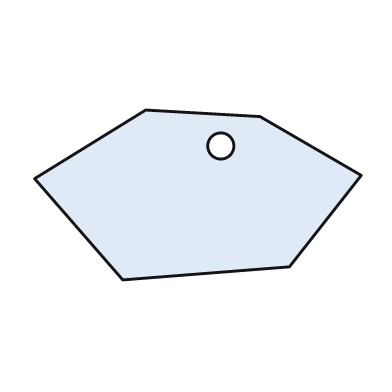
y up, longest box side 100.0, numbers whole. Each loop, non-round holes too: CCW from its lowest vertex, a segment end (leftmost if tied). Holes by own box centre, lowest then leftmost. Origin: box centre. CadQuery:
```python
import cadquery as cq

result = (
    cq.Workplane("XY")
    .moveTo(-23.0, -26.0)
    .lineTo(28.0, -22.0)
    .lineTo(50.0, 6.0)
    .lineTo(19.0, 24.0)
    .lineTo(-16.0, 26.0)
    .lineTo(-50.0, 5.0)
    .close()
    .moveTo(7.0, 15.0)
    .circle(4.0)
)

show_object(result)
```